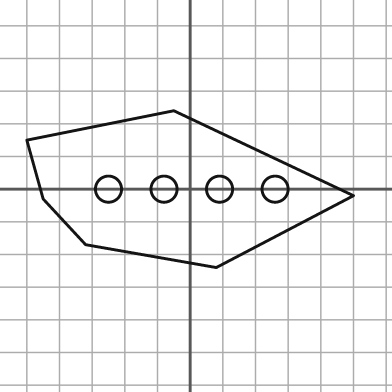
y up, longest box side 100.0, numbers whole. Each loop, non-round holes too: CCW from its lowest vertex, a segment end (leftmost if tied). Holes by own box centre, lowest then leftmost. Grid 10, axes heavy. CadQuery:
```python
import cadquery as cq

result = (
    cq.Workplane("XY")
    .moveTo(8.0, -24.0)
    .lineTo(50.0, -2.0)
    .lineTo(-5.0, 24.0)
    .lineTo(-50.0, 15.0)
    .lineTo(-45.0, -3.0)
    .lineTo(-32.0, -17.0)
    .close()
    .moveTo(-25.0, 0.0)
    .circle(4.0)
    .moveTo(-8.0, 0.0)
    .circle(4.0)
    .moveTo(9.0, 0.0)
    .circle(4.0)
    .moveTo(26.0, 0.0)
    .circle(4.0)
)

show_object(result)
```